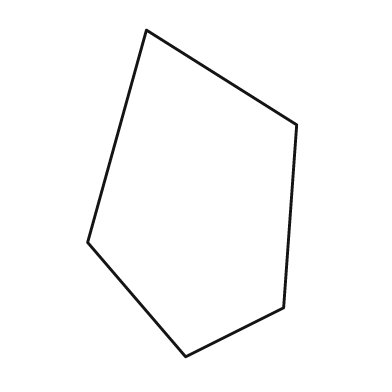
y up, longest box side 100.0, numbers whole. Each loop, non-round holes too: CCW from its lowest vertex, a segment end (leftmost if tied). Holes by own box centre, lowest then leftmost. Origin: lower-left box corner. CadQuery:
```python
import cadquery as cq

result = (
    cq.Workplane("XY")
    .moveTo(30.0, 0.0)
    .lineTo(60.0, 15.0)
    .lineTo(64.0, 71.0)
    .lineTo(18.0, 100.0)
    .lineTo(0.0, 35.0)
    .close()
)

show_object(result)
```